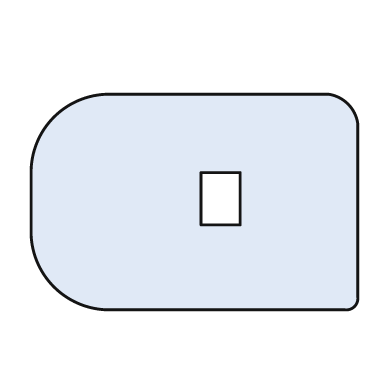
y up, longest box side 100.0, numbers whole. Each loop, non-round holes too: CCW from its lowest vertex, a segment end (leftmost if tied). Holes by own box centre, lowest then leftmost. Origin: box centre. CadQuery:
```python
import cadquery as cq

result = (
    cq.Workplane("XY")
    .moveTo(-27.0, -33.0)
    .lineTo(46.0, -33.0)
    .threePointArc((49.0, -32.0), (50.0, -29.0))
    .lineTo(50.0, 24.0)
    .threePointArc((47.0, 30.0), (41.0, 33.0))
    .lineTo(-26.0, 33.0)
    .threePointArc((-43.0, 26.0), (-50.0, 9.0))
    .lineTo(-50.0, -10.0)
    .threePointArc((-43.0, -26.0), (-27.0, -33.0))
    .close()
    .moveTo(2.0, -7.0)
    .lineTo(14.0, -7.0)
    .lineTo(14.0, 9.0)
    .lineTo(2.0, 9.0)
    .close()
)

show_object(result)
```